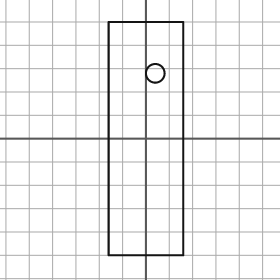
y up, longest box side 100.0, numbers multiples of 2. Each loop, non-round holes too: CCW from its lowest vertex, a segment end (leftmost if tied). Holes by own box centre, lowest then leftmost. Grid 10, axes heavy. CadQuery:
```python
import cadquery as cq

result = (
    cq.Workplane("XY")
    .moveTo(-16.0, -50.0)
    .lineTo(16.0, -50.0)
    .lineTo(16.0, 50.0)
    .lineTo(-16.0, 50.0)
    .close()
    .moveTo(4.0, 28.0)
    .circle(4.0)
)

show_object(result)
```